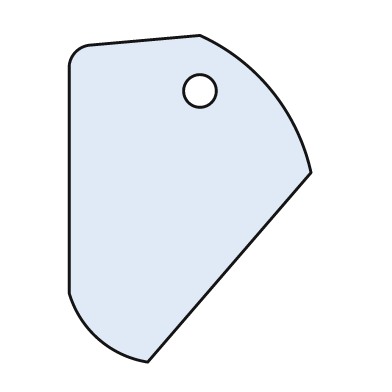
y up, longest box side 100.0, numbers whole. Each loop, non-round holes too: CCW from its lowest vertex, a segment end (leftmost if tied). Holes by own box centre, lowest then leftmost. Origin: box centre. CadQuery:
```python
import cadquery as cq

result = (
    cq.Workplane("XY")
    .moveTo(-13.0, -50.0)
    .lineTo(37.0, 8.0)
    .threePointArc((25.0, 33.0), (3.0, 50.0))
    .lineTo(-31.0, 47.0)
    .threePointArc((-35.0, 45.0), (-37.0, 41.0))
    .lineTo(-37.0, -29.0)
    .threePointArc((-28.0, -43.0), (-13.0, -50.0))
    .close()
    .moveTo(3.0, 33.0)
    .circle(5.0)
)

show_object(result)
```